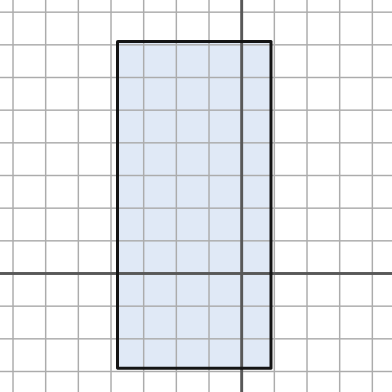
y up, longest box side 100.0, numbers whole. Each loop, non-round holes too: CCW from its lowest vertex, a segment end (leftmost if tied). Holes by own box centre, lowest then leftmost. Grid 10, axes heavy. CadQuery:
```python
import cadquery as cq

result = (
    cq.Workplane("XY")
    .moveTo(-38.0, -29.0)
    .lineTo(9.0, -29.0)
    .lineTo(9.0, 71.0)
    .lineTo(-38.0, 71.0)
    .close()
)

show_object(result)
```